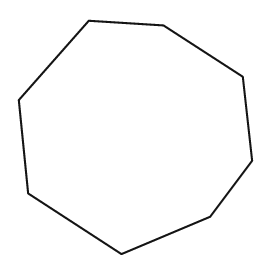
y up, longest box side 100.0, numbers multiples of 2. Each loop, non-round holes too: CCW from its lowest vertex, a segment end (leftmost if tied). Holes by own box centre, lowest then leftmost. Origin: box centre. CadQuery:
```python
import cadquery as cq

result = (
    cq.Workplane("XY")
    .moveTo(-6.0, -50.0)
    .lineTo(32.0, -34.0)
    .lineTo(50.0, -10.0)
    .lineTo(46.0, 26.0)
    .lineTo(12.0, 48.0)
    .lineTo(-20.0, 50.0)
    .lineTo(-50.0, 16.0)
    .lineTo(-46.0, -24.0)
    .close()
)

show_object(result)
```